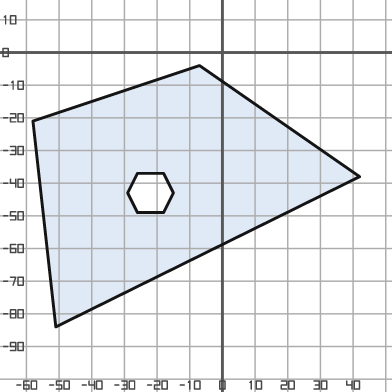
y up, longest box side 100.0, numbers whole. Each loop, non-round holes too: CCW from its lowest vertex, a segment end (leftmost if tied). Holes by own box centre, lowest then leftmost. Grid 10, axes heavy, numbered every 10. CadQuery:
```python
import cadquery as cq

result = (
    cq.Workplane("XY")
    .moveTo(-51.0, -84.0)
    .lineTo(42.0, -38.0)
    .lineTo(-7.0, -4.0)
    .lineTo(-58.0, -21.0)
    .close()
    .moveTo(-26.0, -49.0)
    .lineTo(-18.0, -49.0)
    .lineTo(-15.0, -43.0)
    .lineTo(-18.0, -37.0)
    .lineTo(-26.0, -37.0)
    .lineTo(-29.0, -43.0)
    .close()
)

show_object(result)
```